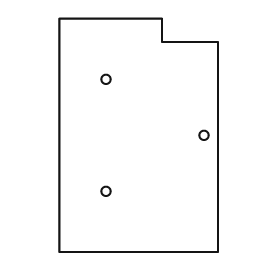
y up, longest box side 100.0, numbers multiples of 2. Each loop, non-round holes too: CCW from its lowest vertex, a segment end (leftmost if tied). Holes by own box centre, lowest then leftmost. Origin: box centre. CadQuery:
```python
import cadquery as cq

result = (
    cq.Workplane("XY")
    .moveTo(-34.0, -50.0)
    .lineTo(34.0, -50.0)
    .lineTo(34.0, 40.0)
    .lineTo(10.0, 40.0)
    .lineTo(10.0, 50.0)
    .lineTo(-34.0, 50.0)
    .close()
    .moveTo(-14.0, -24.0)
    .circle(2.0)
    .moveTo(28.0, 0.0)
    .circle(2.0)
    .moveTo(-14.0, 24.0)
    .circle(2.0)
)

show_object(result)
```